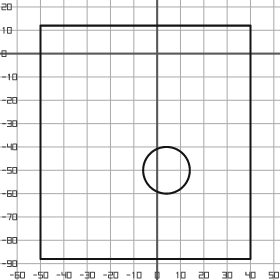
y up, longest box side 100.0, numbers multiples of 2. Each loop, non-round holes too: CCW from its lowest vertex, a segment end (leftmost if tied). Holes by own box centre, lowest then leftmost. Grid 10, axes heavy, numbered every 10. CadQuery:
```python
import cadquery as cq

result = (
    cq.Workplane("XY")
    .moveTo(-50.0, -88.0)
    .lineTo(40.0, -88.0)
    .lineTo(40.0, 12.0)
    .lineTo(-50.0, 12.0)
    .close()
    .moveTo(4.0, -50.0)
    .circle(10.0)
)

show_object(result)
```